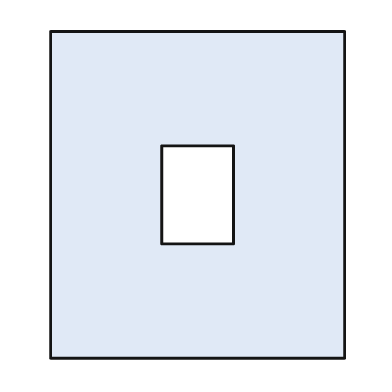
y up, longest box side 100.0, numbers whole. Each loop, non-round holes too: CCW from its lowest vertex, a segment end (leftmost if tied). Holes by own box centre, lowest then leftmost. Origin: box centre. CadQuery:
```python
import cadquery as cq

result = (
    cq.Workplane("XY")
    .moveTo(-45.0, -50.0)
    .lineTo(45.0, -50.0)
    .lineTo(45.0, 50.0)
    .lineTo(-45.0, 50.0)
    .close()
    .moveTo(-11.0, -15.0)
    .lineTo(11.0, -15.0)
    .lineTo(11.0, 15.0)
    .lineTo(-11.0, 15.0)
    .close()
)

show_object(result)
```